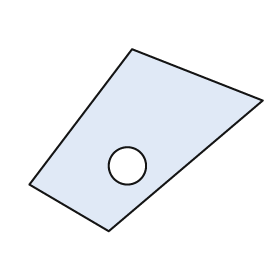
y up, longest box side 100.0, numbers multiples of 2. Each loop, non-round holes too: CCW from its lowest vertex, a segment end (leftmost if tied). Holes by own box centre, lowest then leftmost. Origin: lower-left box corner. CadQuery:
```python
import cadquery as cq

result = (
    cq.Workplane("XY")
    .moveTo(34.0, 0.0)
    .lineTo(100.0, 56.0)
    .lineTo(44.0, 78.0)
    .lineTo(0.0, 20.0)
    .close()
    .moveTo(42.0, 28.0)
    .circle(8.0)
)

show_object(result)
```